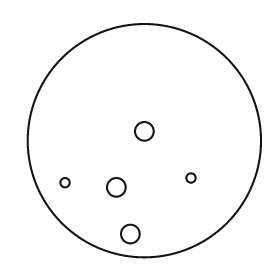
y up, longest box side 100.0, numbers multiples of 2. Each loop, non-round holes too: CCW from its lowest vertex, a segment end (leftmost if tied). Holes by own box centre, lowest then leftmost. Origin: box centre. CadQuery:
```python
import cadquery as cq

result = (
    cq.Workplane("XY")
    .moveTo(0.0, 0.0)
    .circle(50.0)
    .moveTo(-6.0, -40.0)
    .circle(4.0)
    .moveTo(-12.0, -20.0)
    .circle(4.0)
    .moveTo(-34.0, -18.0)
    .circle(2.0)
    .moveTo(20.0, -16.0)
    .circle(2.0)
    .moveTo(0.0, 4.0)
    .circle(4.0)
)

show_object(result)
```